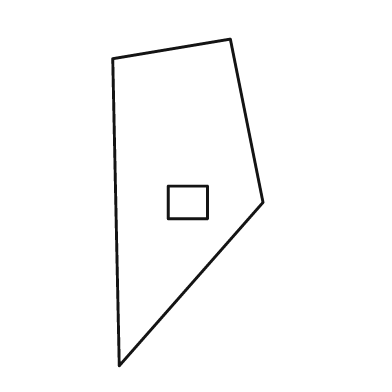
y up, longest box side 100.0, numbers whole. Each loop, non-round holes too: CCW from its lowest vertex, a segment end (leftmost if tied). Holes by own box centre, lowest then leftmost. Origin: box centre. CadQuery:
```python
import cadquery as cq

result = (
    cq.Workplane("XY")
    .moveTo(-21.0, -50.0)
    .lineTo(23.0, 0.0)
    .lineTo(13.0, 50.0)
    .lineTo(-23.0, 44.0)
    .close()
    .moveTo(-6.0, -5.0)
    .lineTo(6.0, -5.0)
    .lineTo(6.0, 5.0)
    .lineTo(-6.0, 5.0)
    .close()
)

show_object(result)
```